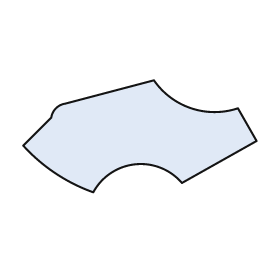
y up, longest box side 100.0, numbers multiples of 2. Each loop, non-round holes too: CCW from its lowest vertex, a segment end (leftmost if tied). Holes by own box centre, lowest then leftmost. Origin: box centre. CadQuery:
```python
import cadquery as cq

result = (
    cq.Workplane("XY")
    .moveTo(-20.0, -24.0)
    .threePointArc((-2.0, -12.0), (18.0, -20.0))
    .lineTo(50.0, -2.0)
    .lineTo(42.0, 12.0)
    .threePointArc((22.0, 12.0), (6.0, 24.0))
    .lineTo(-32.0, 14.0)
    .threePointArc((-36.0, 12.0), (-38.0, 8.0))
    .lineTo(-50.0, -4.0)
    .threePointArc((-36.0, -16.0), (-20.0, -24.0))
    .close()
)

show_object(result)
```